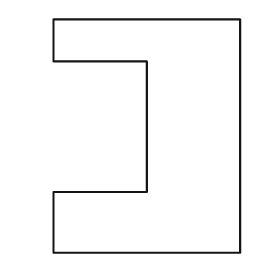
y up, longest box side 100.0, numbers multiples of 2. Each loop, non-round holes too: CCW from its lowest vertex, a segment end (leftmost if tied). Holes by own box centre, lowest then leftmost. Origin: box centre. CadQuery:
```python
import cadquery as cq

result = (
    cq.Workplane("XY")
    .moveTo(-40.0, -50.0)
    .lineTo(40.0, -50.0)
    .lineTo(40.0, 50.0)
    .lineTo(-40.0, 50.0)
    .lineTo(-40.0, 32.0)
    .lineTo(0.0, 32.0)
    .lineTo(0.0, -24.0)
    .lineTo(-40.0, -24.0)
    .close()
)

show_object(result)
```